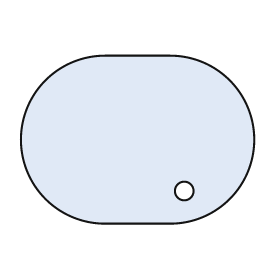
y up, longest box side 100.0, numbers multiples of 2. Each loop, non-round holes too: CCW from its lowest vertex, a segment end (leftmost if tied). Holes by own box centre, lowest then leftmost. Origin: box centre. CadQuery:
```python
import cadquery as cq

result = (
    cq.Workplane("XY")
    .moveTo(-14.0, -36.0)
    .lineTo(14.0, -36.0)
    .threePointArc((50.0, 0.0), (14.0, 36.0))
    .lineTo(-14.0, 36.0)
    .threePointArc((-50.0, 0.0), (-14.0, -36.0))
    .close()
    .moveTo(20.0, -22.0)
    .circle(4.0)
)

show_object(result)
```